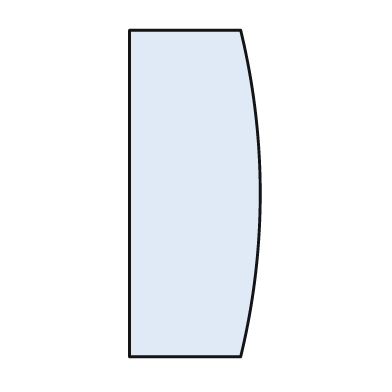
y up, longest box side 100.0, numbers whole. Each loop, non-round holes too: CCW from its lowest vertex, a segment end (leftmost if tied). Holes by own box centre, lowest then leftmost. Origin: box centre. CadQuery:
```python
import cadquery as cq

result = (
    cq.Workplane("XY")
    .moveTo(-20.0, -50.0)
    .lineTo(14.0, -50.0)
    .threePointArc((20.0, 0.0), (14.0, 50.0))
    .lineTo(-20.0, 50.0)
    .close()
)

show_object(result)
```